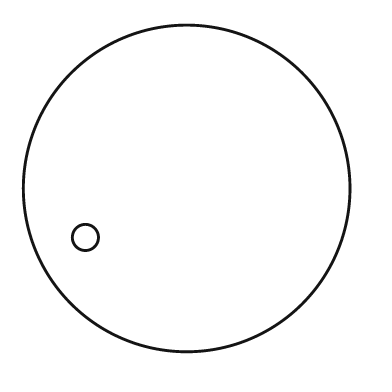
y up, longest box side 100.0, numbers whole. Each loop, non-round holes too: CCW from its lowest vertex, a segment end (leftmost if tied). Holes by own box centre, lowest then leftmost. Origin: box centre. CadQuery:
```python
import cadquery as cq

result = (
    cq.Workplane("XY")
    .moveTo(0.0, 0.0)
    .circle(50.0)
    .moveTo(-31.0, -15.0)
    .circle(4.0)
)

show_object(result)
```